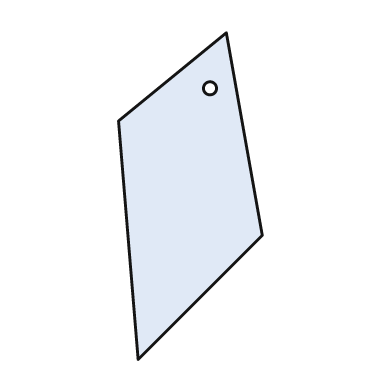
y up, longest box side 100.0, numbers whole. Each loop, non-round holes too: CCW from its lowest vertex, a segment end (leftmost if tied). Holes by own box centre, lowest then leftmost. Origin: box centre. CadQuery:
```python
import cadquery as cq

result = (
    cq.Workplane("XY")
    .moveTo(-16.0, -50.0)
    .lineTo(22.0, -12.0)
    .lineTo(11.0, 50.0)
    .lineTo(-22.0, 23.0)
    .close()
    .moveTo(6.0, 33.0)
    .circle(2.0)
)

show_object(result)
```